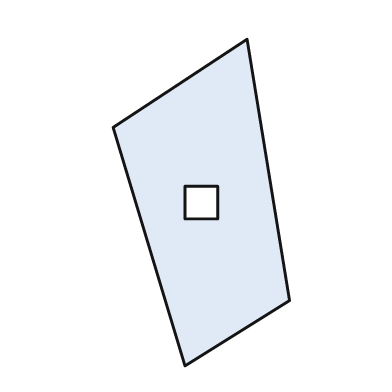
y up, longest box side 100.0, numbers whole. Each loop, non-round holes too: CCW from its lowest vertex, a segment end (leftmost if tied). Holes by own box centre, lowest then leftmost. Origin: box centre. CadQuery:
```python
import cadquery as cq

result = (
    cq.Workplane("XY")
    .moveTo(-5.0, -50.0)
    .lineTo(27.0, -30.0)
    .lineTo(14.0, 50.0)
    .lineTo(-27.0, 23.0)
    .close()
    .moveTo(-5.0, -5.0)
    .lineTo(5.0, -5.0)
    .lineTo(5.0, 5.0)
    .lineTo(-5.0, 5.0)
    .close()
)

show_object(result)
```